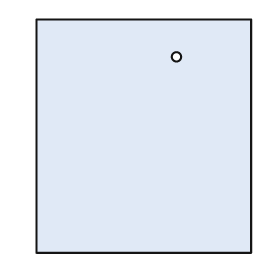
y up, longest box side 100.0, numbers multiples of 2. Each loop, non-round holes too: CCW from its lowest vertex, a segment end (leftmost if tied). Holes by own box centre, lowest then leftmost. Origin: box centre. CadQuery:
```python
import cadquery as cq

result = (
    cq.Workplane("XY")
    .moveTo(-46.0, -50.0)
    .lineTo(46.0, -50.0)
    .lineTo(46.0, 50.0)
    .lineTo(-46.0, 50.0)
    .close()
    .moveTo(14.0, 34.0)
    .circle(2.0)
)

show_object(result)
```